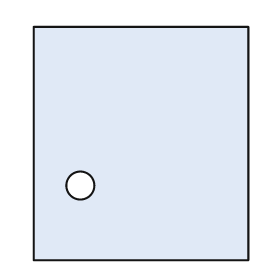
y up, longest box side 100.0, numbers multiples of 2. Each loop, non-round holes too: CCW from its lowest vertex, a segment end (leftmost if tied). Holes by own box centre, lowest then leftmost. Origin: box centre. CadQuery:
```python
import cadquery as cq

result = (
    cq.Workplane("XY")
    .moveTo(-46.0, -50.0)
    .lineTo(46.0, -50.0)
    .lineTo(46.0, 50.0)
    .lineTo(-46.0, 50.0)
    .close()
    .moveTo(-26.0, -18.0)
    .circle(6.0)
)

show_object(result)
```